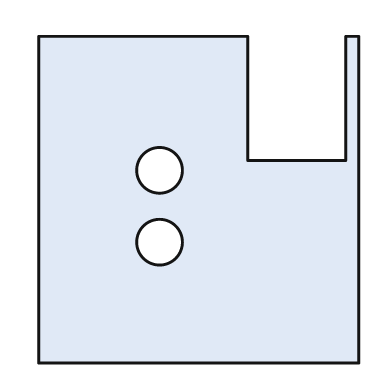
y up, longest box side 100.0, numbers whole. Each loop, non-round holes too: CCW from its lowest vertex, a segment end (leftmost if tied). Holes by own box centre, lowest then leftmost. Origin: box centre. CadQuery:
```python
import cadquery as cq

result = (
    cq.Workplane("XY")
    .moveTo(-49.0, -50.0)
    .lineTo(49.0, -50.0)
    .lineTo(49.0, 50.0)
    .lineTo(45.0, 50.0)
    .lineTo(45.0, 12.0)
    .lineTo(15.0, 12.0)
    .lineTo(15.0, 50.0)
    .lineTo(-49.0, 50.0)
    .close()
    .moveTo(-12.0, -13.0)
    .circle(7.0)
    .moveTo(-12.0, 9.0)
    .circle(7.0)
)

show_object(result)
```